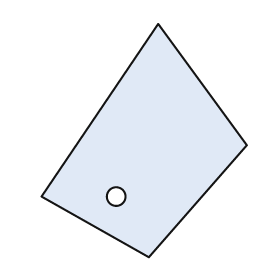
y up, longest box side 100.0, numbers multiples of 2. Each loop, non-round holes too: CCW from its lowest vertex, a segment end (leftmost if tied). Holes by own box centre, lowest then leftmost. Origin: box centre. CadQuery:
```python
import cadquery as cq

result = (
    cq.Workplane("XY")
    .moveTo(2.0, -50.0)
    .lineTo(44.0, -2.0)
    .lineTo(6.0, 50.0)
    .lineTo(-44.0, -24.0)
    .close()
    .moveTo(-12.0, -24.0)
    .circle(4.0)
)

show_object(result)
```